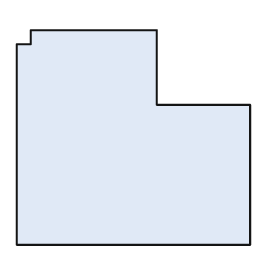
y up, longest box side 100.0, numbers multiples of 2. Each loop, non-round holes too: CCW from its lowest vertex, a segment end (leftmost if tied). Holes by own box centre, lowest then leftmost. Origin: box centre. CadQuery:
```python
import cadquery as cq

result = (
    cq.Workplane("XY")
    .moveTo(-50.0, -46.0)
    .lineTo(50.0, -46.0)
    .lineTo(50.0, 14.0)
    .lineTo(10.0, 14.0)
    .lineTo(10.0, 46.0)
    .lineTo(-44.0, 46.0)
    .lineTo(-44.0, 40.0)
    .lineTo(-50.0, 40.0)
    .close()
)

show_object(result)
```